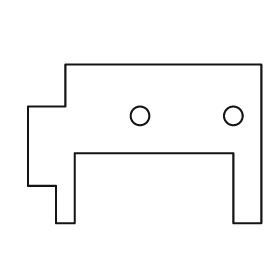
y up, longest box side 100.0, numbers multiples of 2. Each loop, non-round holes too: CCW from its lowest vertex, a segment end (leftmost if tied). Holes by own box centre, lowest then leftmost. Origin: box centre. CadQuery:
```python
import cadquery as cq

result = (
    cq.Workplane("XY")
    .moveTo(-38.0, -34.0)
    .lineTo(-30.0, -34.0)
    .lineTo(-30.0, -4.0)
    .lineTo(38.0, -4.0)
    .lineTo(38.0, -34.0)
    .lineTo(50.0, -34.0)
    .lineTo(50.0, 34.0)
    .lineTo(-34.0, 34.0)
    .lineTo(-34.0, 16.0)
    .lineTo(-50.0, 16.0)
    .lineTo(-50.0, -18.0)
    .lineTo(-38.0, -18.0)
    .close()
    .moveTo(-2.0, 12.0)
    .circle(4.0)
    .moveTo(38.0, 12.0)
    .circle(4.0)
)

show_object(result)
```